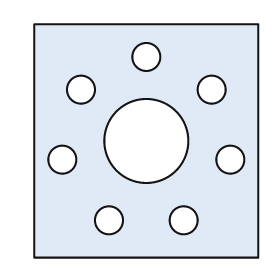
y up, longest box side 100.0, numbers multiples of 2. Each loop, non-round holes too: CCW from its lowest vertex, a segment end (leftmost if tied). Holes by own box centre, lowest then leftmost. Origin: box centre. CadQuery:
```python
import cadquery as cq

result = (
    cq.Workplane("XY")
    .moveTo(-48.0, -50.0)
    .lineTo(48.0, -50.0)
    .lineTo(48.0, 50.0)
    .lineTo(-48.0, 50.0)
    .close()
    .moveTo(-16.0, -34.0)
    .circle(6.0)
    .moveTo(16.0, -34.0)
    .circle(6.0)
    .moveTo(-36.0, -8.0)
    .circle(6.0)
    .moveTo(36.0, -8.0)
    .circle(6.0)
    .moveTo(0.0, 0.0)
    .circle(18.0)
    .moveTo(-28.0, 22.0)
    .circle(6.0)
    .moveTo(28.0, 22.0)
    .circle(6.0)
    .moveTo(0.0, 36.0)
    .circle(6.0)
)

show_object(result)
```